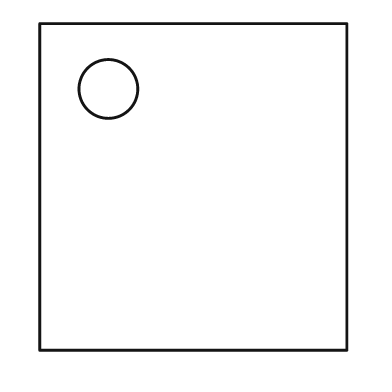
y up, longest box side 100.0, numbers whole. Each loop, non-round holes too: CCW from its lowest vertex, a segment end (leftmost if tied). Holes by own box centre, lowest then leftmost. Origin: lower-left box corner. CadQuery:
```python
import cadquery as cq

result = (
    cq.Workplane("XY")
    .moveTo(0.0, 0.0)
    .lineTo(94.0, 0.0)
    .lineTo(94.0, 100.0)
    .lineTo(0.0, 100.0)
    .close()
    .moveTo(21.0, 80.0)
    .circle(9.0)
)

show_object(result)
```